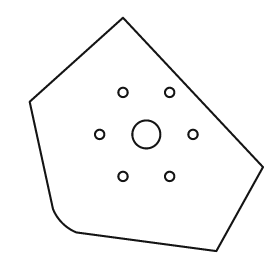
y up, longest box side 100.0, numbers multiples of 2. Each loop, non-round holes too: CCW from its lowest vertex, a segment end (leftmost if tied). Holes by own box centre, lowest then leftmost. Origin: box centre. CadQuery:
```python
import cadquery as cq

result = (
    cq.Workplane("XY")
    .moveTo(30.0, -50.0)
    .lineTo(50.0, -14.0)
    .lineTo(-10.0, 50.0)
    .lineTo(-50.0, 14.0)
    .lineTo(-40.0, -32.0)
    .threePointArc((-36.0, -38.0), (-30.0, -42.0))
    .close()
    .moveTo(-10.0, -18.0)
    .circle(2.0)
    .moveTo(10.0, -18.0)
    .circle(2.0)
    .moveTo(-20.0, 0.0)
    .circle(2.0)
    .moveTo(0.0, 0.0)
    .circle(6.0)
    .moveTo(20.0, 0.0)
    .circle(2.0)
    .moveTo(-10.0, 18.0)
    .circle(2.0)
    .moveTo(10.0, 18.0)
    .circle(2.0)
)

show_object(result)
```